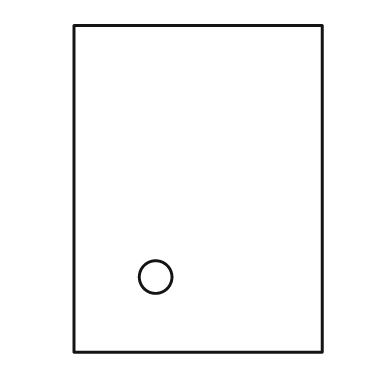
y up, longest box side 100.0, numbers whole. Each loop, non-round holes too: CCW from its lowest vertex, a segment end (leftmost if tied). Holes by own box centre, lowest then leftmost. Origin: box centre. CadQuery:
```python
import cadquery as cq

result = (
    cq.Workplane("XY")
    .moveTo(-38.0, -50.0)
    .lineTo(38.0, -50.0)
    .lineTo(38.0, 50.0)
    .lineTo(-38.0, 50.0)
    .close()
    .moveTo(-13.0, -27.0)
    .circle(5.0)
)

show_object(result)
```